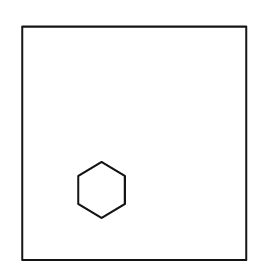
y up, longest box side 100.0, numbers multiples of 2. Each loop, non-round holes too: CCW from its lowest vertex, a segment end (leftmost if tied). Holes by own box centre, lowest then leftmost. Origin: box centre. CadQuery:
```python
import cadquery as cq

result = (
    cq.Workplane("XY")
    .moveTo(-48.0, -50.0)
    .lineTo(48.0, -50.0)
    .lineTo(48.0, 50.0)
    .lineTo(-48.0, 50.0)
    .close()
    .moveTo(-14.0, -32.0)
    .lineTo(-4.0, -26.0)
    .lineTo(-4.0, -14.0)
    .lineTo(-14.0, -8.0)
    .lineTo(-24.0, -14.0)
    .lineTo(-24.0, -26.0)
    .close()
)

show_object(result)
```